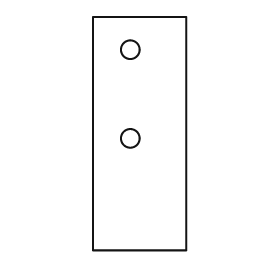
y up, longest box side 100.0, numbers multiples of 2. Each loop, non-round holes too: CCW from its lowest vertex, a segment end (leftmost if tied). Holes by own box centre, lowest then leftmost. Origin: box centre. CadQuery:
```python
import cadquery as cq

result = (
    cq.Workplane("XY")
    .moveTo(-20.0, -50.0)
    .lineTo(20.0, -50.0)
    .lineTo(20.0, 50.0)
    .lineTo(-20.0, 50.0)
    .close()
    .moveTo(-4.0, -2.0)
    .circle(4.0)
    .moveTo(-4.0, 36.0)
    .circle(4.0)
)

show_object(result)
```